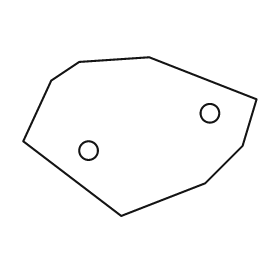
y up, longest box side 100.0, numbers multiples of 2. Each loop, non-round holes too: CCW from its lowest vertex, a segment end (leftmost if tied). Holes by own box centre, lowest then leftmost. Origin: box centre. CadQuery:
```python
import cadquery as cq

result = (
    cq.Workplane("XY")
    .moveTo(-8.0, -34.0)
    .lineTo(28.0, -20.0)
    .lineTo(44.0, -4.0)
    .lineTo(50.0, 16.0)
    .lineTo(4.0, 34.0)
    .lineTo(-26.0, 32.0)
    .lineTo(-38.0, 24.0)
    .lineTo(-50.0, -2.0)
    .close()
    .moveTo(-22.0, -6.0)
    .circle(4.0)
    .moveTo(30.0, 10.0)
    .circle(4.0)
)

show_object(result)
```